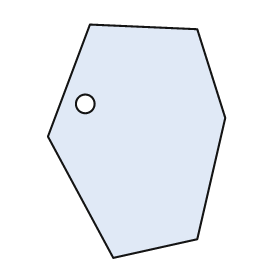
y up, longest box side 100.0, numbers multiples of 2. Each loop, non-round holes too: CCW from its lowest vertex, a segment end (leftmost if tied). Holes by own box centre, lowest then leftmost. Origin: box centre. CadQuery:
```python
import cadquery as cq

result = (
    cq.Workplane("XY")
    .moveTo(-10.0, -50.0)
    .lineTo(26.0, -42.0)
    .lineTo(38.0, 10.0)
    .lineTo(26.0, 48.0)
    .lineTo(-20.0, 50.0)
    .lineTo(-38.0, 2.0)
    .close()
    .moveTo(-22.0, 16.0)
    .circle(4.0)
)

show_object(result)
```